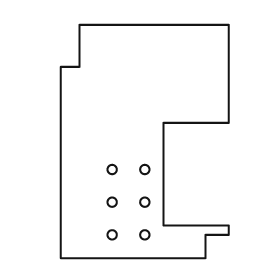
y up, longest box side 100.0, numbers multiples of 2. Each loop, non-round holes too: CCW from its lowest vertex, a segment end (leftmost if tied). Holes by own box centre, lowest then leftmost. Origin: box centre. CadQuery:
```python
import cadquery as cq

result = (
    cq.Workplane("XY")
    .moveTo(-36.0, -50.0)
    .lineTo(26.0, -50.0)
    .lineTo(26.0, -40.0)
    .lineTo(36.0, -40.0)
    .lineTo(36.0, -36.0)
    .lineTo(8.0, -36.0)
    .lineTo(8.0, 8.0)
    .lineTo(36.0, 8.0)
    .lineTo(36.0, 50.0)
    .lineTo(-28.0, 50.0)
    .lineTo(-28.0, 32.0)
    .lineTo(-36.0, 32.0)
    .close()
    .moveTo(-14.0, -40.0)
    .circle(2.0)
    .moveTo(0.0, -40.0)
    .circle(2.0)
    .moveTo(-14.0, -26.0)
    .circle(2.0)
    .moveTo(0.0, -26.0)
    .circle(2.0)
    .moveTo(-14.0, -12.0)
    .circle(2.0)
    .moveTo(0.0, -12.0)
    .circle(2.0)
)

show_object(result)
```